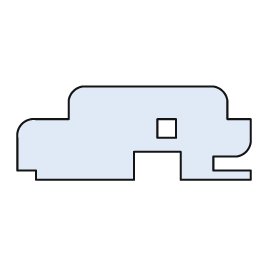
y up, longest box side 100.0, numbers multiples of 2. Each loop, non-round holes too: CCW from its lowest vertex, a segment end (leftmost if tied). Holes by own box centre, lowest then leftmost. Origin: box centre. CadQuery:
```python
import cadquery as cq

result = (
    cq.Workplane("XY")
    .moveTo(-42.0, -20.0)
    .lineTo(0.0, -20.0)
    .lineTo(0.0, -8.0)
    .lineTo(20.0, -8.0)
    .lineTo(20.0, -20.0)
    .lineTo(50.0, -20.0)
    .lineTo(50.0, -16.0)
    .lineTo(34.0, -16.0)
    .lineTo(34.0, -10.0)
    .lineTo(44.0, -10.0)
    .threePointArc((48.0, -8.0), (50.0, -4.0))
    .lineTo(50.0, 6.0)
    .lineTo(40.0, 6.0)
    .lineTo(40.0, 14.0)
    .threePointArc((38.0, 18.0), (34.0, 20.0))
    .lineTo(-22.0, 20.0)
    .threePointArc((-26.0, 18.0), (-28.0, 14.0))
    .lineTo(-28.0, 6.0)
    .lineTo(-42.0, 6.0)
    .threePointArc((-48.0, 4.0), (-50.0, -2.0))
    .lineTo(-50.0, -16.0)
    .lineTo(-42.0, -16.0)
    .close()
    .moveTo(10.0, -2.0)
    .lineTo(18.0, -2.0)
    .lineTo(18.0, 6.0)
    .lineTo(10.0, 6.0)
    .close()
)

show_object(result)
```